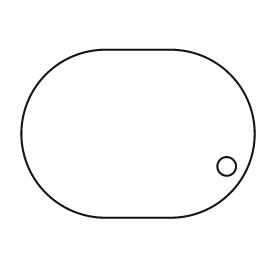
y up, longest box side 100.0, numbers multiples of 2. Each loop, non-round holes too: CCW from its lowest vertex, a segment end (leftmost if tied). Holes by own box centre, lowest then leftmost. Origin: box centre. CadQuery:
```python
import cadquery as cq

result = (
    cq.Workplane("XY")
    .moveTo(-14.0, -36.0)
    .lineTo(14.0, -36.0)
    .threePointArc((50.0, 0.0), (14.0, 36.0))
    .lineTo(-14.0, 36.0)
    .threePointArc((-50.0, 0.0), (-14.0, -36.0))
    .close()
    .moveTo(38.0, -14.0)
    .circle(4.0)
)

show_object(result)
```